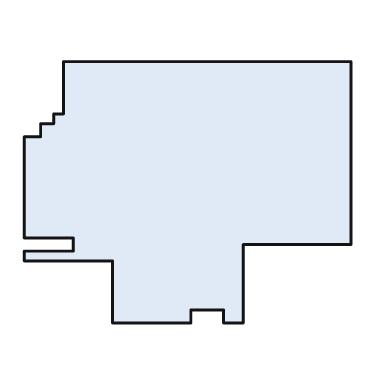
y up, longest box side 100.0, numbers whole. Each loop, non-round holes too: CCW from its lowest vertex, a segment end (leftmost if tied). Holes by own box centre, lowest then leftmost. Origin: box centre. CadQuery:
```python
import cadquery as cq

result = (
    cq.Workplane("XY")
    .moveTo(-23.0, -40.0)
    .lineTo(1.0, -40.0)
    .lineTo(1.0, -36.0)
    .lineTo(11.0, -36.0)
    .lineTo(11.0, -40.0)
    .lineTo(17.0, -40.0)
    .lineTo(17.0, -16.0)
    .lineTo(50.0, -16.0)
    .lineTo(50.0, 40.0)
    .lineTo(-38.0, 40.0)
    .lineTo(-38.0, 24.0)
    .lineTo(-41.0, 24.0)
    .lineTo(-41.0, 21.0)
    .lineTo(-45.0, 21.0)
    .lineTo(-45.0, 17.0)
    .lineTo(-50.0, 17.0)
    .lineTo(-50.0, -14.0)
    .lineTo(-35.0, -14.0)
    .lineTo(-35.0, -18.0)
    .lineTo(-50.0, -18.0)
    .lineTo(-50.0, -21.0)
    .lineTo(-23.0, -21.0)
    .close()
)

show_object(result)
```